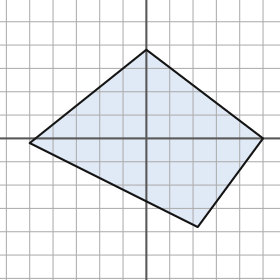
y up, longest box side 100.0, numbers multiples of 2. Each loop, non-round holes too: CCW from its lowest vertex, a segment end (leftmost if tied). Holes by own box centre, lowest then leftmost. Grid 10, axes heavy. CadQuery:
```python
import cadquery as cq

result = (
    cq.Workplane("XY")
    .moveTo(22.0, -38.0)
    .lineTo(50.0, 0.0)
    .lineTo(0.0, 38.0)
    .lineTo(-50.0, -2.0)
    .close()
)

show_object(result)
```